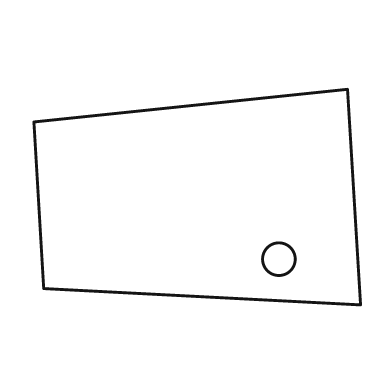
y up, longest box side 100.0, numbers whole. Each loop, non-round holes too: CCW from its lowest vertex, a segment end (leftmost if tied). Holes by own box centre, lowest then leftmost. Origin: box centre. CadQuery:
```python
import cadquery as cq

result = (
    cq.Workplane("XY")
    .moveTo(50.0, -33.0)
    .lineTo(46.0, 33.0)
    .lineTo(-50.0, 23.0)
    .lineTo(-47.0, -28.0)
    .close()
    .moveTo(25.0, -19.0)
    .circle(5.0)
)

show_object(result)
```